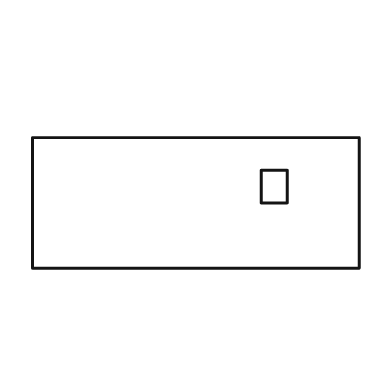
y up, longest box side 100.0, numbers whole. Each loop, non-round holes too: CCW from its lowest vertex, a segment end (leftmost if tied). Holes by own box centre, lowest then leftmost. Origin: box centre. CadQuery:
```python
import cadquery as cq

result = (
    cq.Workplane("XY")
    .moveTo(-50.0, -20.0)
    .lineTo(50.0, -20.0)
    .lineTo(50.0, 20.0)
    .lineTo(-50.0, 20.0)
    .close()
    .moveTo(20.0, 0.0)
    .lineTo(28.0, 0.0)
    .lineTo(28.0, 10.0)
    .lineTo(20.0, 10.0)
    .close()
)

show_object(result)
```